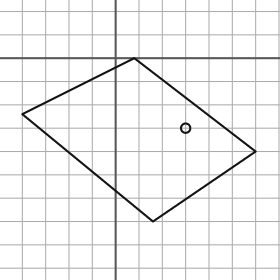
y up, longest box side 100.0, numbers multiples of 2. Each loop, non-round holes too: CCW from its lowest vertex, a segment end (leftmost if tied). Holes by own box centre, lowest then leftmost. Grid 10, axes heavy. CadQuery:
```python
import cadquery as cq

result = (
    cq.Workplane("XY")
    .moveTo(16.0, -70.0)
    .lineTo(60.0, -40.0)
    .lineTo(8.0, 0.0)
    .lineTo(-40.0, -24.0)
    .close()
    .moveTo(30.0, -30.0)
    .circle(2.0)
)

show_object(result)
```